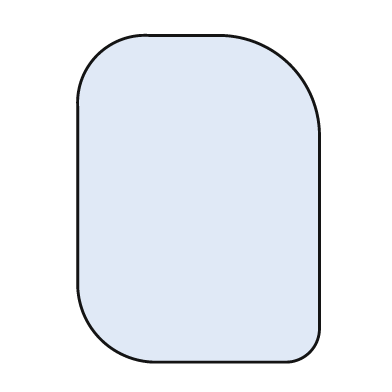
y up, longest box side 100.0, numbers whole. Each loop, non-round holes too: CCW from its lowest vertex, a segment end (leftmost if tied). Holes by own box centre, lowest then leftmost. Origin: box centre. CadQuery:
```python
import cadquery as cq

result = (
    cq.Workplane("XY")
    .moveTo(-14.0, -50.0)
    .lineTo(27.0, -50.0)
    .threePointArc((34.0, -47.0), (37.0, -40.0))
    .lineTo(37.0, 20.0)
    .threePointArc((28.0, 41.0), (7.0, 50.0))
    .lineTo(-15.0, 50.0)
    .threePointArc((-31.0, 44.0), (-37.0, 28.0))
    .lineTo(-37.0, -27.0)
    .threePointArc((-30.0, -43.0), (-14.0, -50.0))
    .close()
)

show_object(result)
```